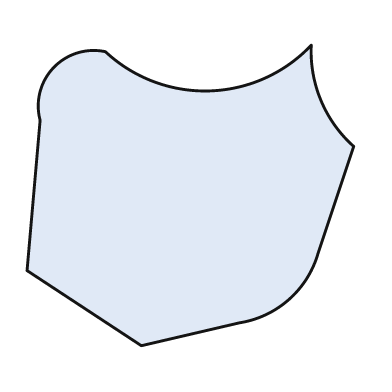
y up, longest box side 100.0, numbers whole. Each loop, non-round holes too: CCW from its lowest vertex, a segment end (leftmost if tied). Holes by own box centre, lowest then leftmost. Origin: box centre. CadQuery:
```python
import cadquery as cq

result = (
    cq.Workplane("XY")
    .moveTo(-15.0, -46.0)
    .lineTo(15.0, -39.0)
    .threePointArc((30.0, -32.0), (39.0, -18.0))
    .lineTo(50.0, 15.0)
    .threePointArc((40.0, 29.0), (37.0, 46.0))
    .threePointArc((6.0, 32.0), (-26.0, 44.0))
    .threePointArc((-42.0, 39.0), (-46.0, 23.0))
    .lineTo(-50.0, -23.0)
    .close()
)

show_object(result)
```